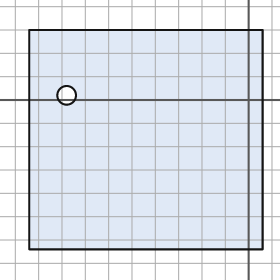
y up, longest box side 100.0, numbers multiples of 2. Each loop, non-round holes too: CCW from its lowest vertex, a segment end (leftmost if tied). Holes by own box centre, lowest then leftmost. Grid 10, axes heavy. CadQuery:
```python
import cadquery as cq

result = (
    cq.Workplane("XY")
    .moveTo(-94.0, -64.0)
    .lineTo(6.0, -64.0)
    .lineTo(6.0, 30.0)
    .lineTo(-94.0, 30.0)
    .close()
    .moveTo(-78.0, 2.0)
    .circle(4.0)
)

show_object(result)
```